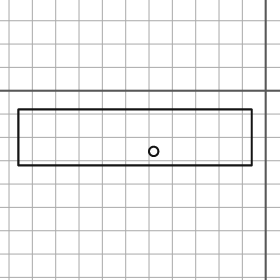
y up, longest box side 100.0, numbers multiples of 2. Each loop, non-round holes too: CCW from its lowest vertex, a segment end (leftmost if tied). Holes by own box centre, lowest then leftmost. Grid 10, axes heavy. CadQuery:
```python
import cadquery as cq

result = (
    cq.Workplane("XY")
    .moveTo(-106.0, -32.0)
    .lineTo(-6.0, -32.0)
    .lineTo(-6.0, -8.0)
    .lineTo(-106.0, -8.0)
    .close()
    .moveTo(-48.0, -26.0)
    .circle(2.0)
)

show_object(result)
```